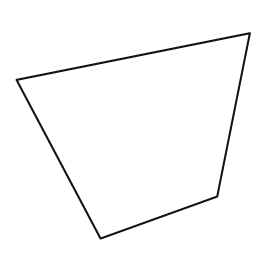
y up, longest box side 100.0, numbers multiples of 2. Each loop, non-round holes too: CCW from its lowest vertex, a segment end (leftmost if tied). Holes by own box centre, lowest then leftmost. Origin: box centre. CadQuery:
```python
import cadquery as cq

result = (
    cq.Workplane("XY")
    .moveTo(-14.0, -44.0)
    .lineTo(36.0, -26.0)
    .lineTo(50.0, 44.0)
    .lineTo(-50.0, 24.0)
    .close()
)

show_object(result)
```